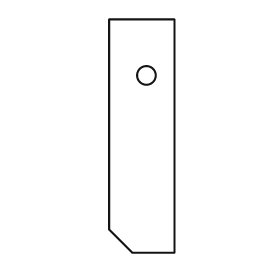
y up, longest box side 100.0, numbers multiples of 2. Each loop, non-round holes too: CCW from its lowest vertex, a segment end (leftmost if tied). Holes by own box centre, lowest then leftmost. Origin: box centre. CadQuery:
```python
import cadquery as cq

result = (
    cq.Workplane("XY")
    .moveTo(-4.0, -50.0)
    .lineTo(14.0, -50.0)
    .lineTo(14.0, 50.0)
    .lineTo(-14.0, 50.0)
    .lineTo(-14.0, -40.0)
    .close()
    .moveTo(2.0, 26.0)
    .circle(4.0)
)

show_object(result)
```